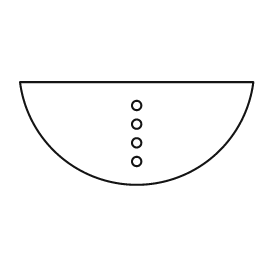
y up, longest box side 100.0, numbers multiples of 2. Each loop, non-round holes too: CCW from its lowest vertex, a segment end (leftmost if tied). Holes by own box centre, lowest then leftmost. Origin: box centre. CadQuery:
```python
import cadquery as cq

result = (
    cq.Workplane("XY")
    .moveTo(-50.0, 22.0)
    .threePointArc((0.0, -22.0), (50.0, 22.0))
    .close()
    .moveTo(0.0, -12.0)
    .circle(2.0)
    .moveTo(0.0, -4.0)
    .circle(2.0)
    .moveTo(0.0, 4.0)
    .circle(2.0)
    .moveTo(0.0, 12.0)
    .circle(2.0)
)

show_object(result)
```